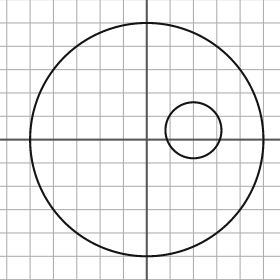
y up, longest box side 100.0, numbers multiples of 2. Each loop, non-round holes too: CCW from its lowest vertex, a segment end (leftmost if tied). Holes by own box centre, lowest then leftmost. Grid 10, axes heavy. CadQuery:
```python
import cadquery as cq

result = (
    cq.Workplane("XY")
    .moveTo(0.0, 0.0)
    .circle(50.0)
    .moveTo(20.0, 4.0)
    .circle(12.0)
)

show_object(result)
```